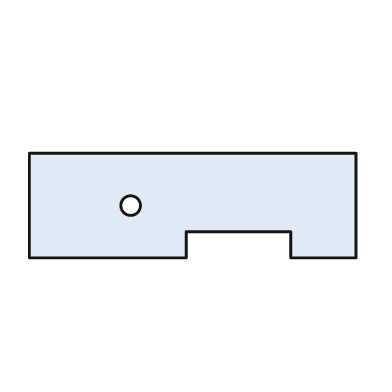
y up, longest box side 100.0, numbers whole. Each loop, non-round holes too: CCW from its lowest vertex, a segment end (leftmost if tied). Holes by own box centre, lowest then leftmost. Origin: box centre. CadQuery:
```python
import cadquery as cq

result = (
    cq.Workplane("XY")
    .moveTo(-50.0, -16.0)
    .lineTo(-2.0, -16.0)
    .lineTo(-2.0, -8.0)
    .lineTo(30.0, -8.0)
    .lineTo(30.0, -16.0)
    .lineTo(50.0, -16.0)
    .lineTo(50.0, 16.0)
    .lineTo(-50.0, 16.0)
    .close()
    .moveTo(-19.0, 0.0)
    .circle(3.0)
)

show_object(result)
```